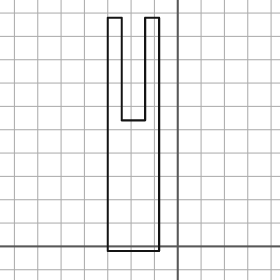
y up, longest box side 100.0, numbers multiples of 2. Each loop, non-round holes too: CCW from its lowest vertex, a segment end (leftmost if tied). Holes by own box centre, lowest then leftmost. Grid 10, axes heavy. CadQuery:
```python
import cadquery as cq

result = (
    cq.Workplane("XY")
    .moveTo(-30.0, -2.0)
    .lineTo(-8.0, -2.0)
    .lineTo(-8.0, 98.0)
    .lineTo(-14.0, 98.0)
    .lineTo(-14.0, 54.0)
    .lineTo(-24.0, 54.0)
    .lineTo(-24.0, 98.0)
    .lineTo(-30.0, 98.0)
    .close()
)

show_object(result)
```